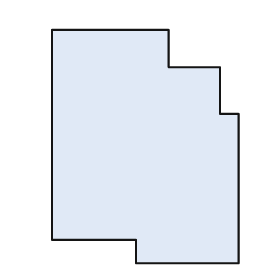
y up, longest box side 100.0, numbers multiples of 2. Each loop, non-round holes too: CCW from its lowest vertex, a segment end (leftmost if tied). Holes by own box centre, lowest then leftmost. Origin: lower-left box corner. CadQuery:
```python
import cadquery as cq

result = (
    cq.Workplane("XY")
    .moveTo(36.0, 0.0)
    .lineTo(80.0, 0.0)
    .lineTo(80.0, 64.0)
    .lineTo(72.0, 64.0)
    .lineTo(72.0, 84.0)
    .lineTo(50.0, 84.0)
    .lineTo(50.0, 100.0)
    .lineTo(0.0, 100.0)
    .lineTo(0.0, 10.0)
    .lineTo(36.0, 10.0)
    .close()
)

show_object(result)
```